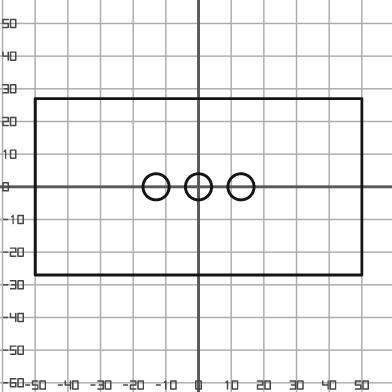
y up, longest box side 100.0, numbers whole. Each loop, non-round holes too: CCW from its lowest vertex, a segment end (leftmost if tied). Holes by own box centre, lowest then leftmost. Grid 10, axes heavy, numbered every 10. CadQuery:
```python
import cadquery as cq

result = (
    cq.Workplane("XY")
    .moveTo(-50.0, -27.0)
    .lineTo(50.0, -27.0)
    .lineTo(50.0, 27.0)
    .lineTo(-50.0, 27.0)
    .close()
    .moveTo(-13.0, 0.0)
    .circle(4.0)
    .moveTo(0.0, 0.0)
    .circle(4.0)
    .moveTo(13.0, 0.0)
    .circle(4.0)
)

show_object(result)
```